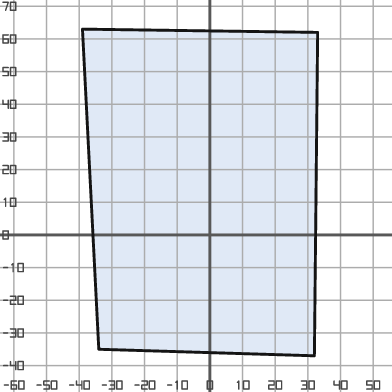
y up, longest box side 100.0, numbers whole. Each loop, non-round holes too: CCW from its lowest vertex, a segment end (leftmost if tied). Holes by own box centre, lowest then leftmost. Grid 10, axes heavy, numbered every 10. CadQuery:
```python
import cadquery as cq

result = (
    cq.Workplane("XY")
    .moveTo(32.0, -37.0)
    .lineTo(33.0, 62.0)
    .lineTo(-39.0, 63.0)
    .lineTo(-34.0, -35.0)
    .close()
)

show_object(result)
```